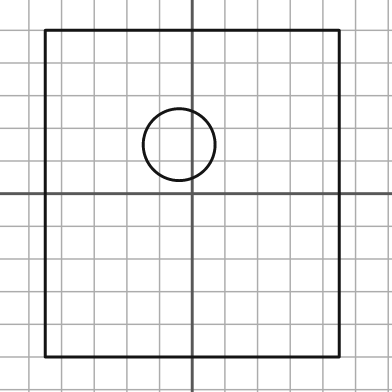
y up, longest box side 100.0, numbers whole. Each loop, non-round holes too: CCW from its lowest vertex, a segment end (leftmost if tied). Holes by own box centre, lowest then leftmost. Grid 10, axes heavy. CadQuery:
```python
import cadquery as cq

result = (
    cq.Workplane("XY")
    .moveTo(-45.0, -50.0)
    .lineTo(45.0, -50.0)
    .lineTo(45.0, 50.0)
    .lineTo(-45.0, 50.0)
    .close()
    .moveTo(-4.0, 15.0)
    .circle(11.0)
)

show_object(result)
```